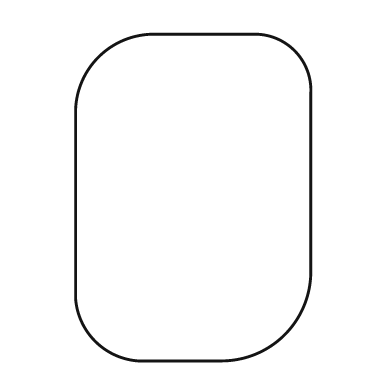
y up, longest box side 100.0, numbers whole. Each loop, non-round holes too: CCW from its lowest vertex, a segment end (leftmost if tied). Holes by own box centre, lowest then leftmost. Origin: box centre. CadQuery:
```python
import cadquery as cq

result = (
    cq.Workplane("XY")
    .moveTo(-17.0, -50.0)
    .lineTo(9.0, -50.0)
    .threePointArc((28.0, -42.0), (36.0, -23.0))
    .lineTo(36.0, 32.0)
    .threePointArc((31.0, 45.0), (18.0, 50.0))
    .lineTo(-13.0, 50.0)
    .threePointArc((-29.0, 43.0), (-36.0, 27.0))
    .lineTo(-36.0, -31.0)
    .threePointArc((-30.0, -44.0), (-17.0, -50.0))
    .close()
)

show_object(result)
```